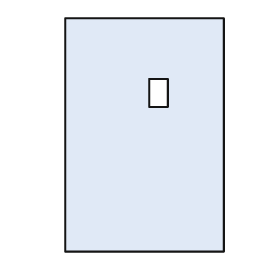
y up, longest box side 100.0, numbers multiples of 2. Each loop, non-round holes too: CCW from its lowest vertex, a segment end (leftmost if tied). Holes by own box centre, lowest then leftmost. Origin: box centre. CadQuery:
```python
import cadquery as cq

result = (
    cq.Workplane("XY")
    .moveTo(-34.0, -50.0)
    .lineTo(34.0, -50.0)
    .lineTo(34.0, 50.0)
    .lineTo(-34.0, 50.0)
    .close()
    .moveTo(2.0, 12.0)
    .lineTo(10.0, 12.0)
    .lineTo(10.0, 24.0)
    .lineTo(2.0, 24.0)
    .close()
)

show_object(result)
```